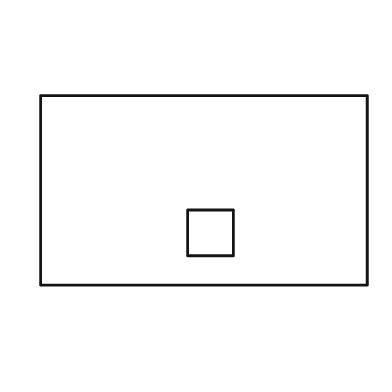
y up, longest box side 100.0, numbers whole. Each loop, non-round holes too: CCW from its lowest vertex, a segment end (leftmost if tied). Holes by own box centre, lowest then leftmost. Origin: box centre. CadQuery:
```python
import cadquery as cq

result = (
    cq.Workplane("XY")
    .moveTo(-50.0, -29.0)
    .lineTo(50.0, -29.0)
    .lineTo(50.0, 29.0)
    .lineTo(-50.0, 29.0)
    .close()
    .moveTo(-5.0, -20.0)
    .lineTo(9.0, -20.0)
    .lineTo(9.0, -6.0)
    .lineTo(-5.0, -6.0)
    .close()
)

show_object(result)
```